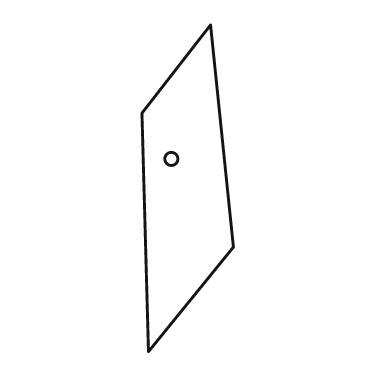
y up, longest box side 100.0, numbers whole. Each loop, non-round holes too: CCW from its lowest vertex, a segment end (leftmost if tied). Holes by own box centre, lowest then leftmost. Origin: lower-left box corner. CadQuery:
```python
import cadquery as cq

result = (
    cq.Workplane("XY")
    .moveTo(2.0, 0.0)
    .lineTo(28.0, 32.0)
    .lineTo(21.0, 100.0)
    .lineTo(0.0, 73.0)
    .close()
    .moveTo(9.0, 59.0)
    .circle(2.0)
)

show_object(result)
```